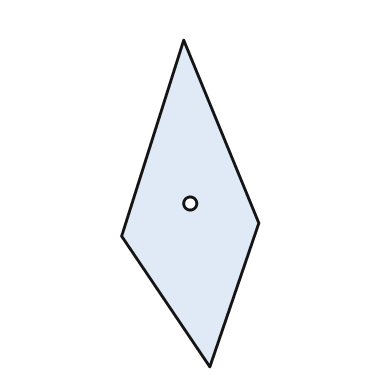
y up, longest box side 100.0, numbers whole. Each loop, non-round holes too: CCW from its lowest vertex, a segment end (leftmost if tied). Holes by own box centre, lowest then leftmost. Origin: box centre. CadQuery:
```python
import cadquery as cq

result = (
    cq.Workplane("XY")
    .moveTo(6.0, -50.0)
    .lineTo(21.0, -6.0)
    .lineTo(-2.0, 50.0)
    .lineTo(-21.0, -10.0)
    .close()
    .moveTo(0.0, 0.0)
    .circle(2.0)
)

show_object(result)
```